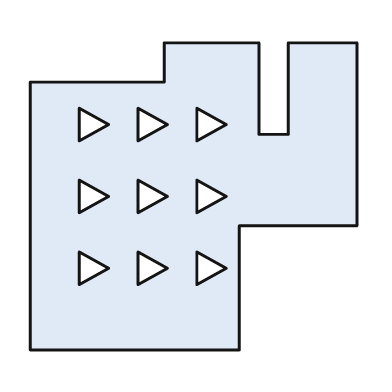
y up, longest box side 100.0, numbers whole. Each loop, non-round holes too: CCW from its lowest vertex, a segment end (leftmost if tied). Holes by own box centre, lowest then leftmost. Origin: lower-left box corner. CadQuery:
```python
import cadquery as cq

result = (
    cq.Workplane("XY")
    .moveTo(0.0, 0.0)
    .lineTo(64.0, 0.0)
    .lineTo(64.0, 38.0)
    .lineTo(100.0, 38.0)
    .lineTo(100.0, 94.0)
    .lineTo(79.0, 94.0)
    .lineTo(79.0, 66.0)
    .lineTo(70.0, 66.0)
    .lineTo(70.0, 94.0)
    .lineTo(41.0, 94.0)
    .lineTo(41.0, 82.0)
    .lineTo(0.0, 82.0)
    .close()
    .moveTo(15.0, 20.0)
    .lineTo(24.0, 25.0)
    .lineTo(15.0, 30.0)
    .close()
    .moveTo(33.0, 20.0)
    .lineTo(42.0, 25.0)
    .lineTo(33.0, 30.0)
    .close()
    .moveTo(51.0, 20.0)
    .lineTo(60.0, 25.0)
    .lineTo(51.0, 30.0)
    .close()
    .moveTo(15.0, 42.0)
    .lineTo(24.0, 47.0)
    .lineTo(15.0, 52.0)
    .close()
    .moveTo(33.0, 42.0)
    .lineTo(42.0, 47.0)
    .lineTo(33.0, 52.0)
    .close()
    .moveTo(51.0, 42.0)
    .lineTo(60.0, 47.0)
    .lineTo(51.0, 52.0)
    .close()
    .moveTo(15.0, 64.0)
    .lineTo(24.0, 69.0)
    .lineTo(15.0, 74.0)
    .close()
    .moveTo(33.0, 64.0)
    .lineTo(42.0, 69.0)
    .lineTo(33.0, 74.0)
    .close()
    .moveTo(51.0, 64.0)
    .lineTo(60.0, 69.0)
    .lineTo(51.0, 74.0)
    .close()
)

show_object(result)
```